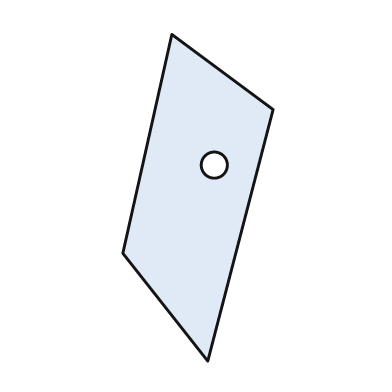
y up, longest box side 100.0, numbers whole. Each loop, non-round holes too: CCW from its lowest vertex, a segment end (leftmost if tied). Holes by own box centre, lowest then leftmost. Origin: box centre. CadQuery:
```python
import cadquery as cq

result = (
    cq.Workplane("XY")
    .moveTo(3.0, -50.0)
    .lineTo(23.0, 27.0)
    .lineTo(-8.0, 50.0)
    .lineTo(-23.0, -17.0)
    .close()
    .moveTo(5.0, 10.0)
    .circle(4.0)
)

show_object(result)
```